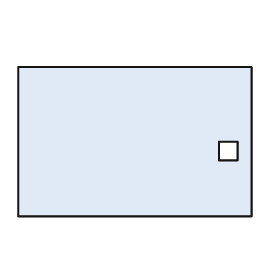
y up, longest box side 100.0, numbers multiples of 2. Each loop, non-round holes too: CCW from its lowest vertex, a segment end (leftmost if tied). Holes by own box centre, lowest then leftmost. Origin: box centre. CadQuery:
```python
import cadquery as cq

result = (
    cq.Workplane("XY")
    .moveTo(-50.0, -32.0)
    .lineTo(50.0, -32.0)
    .lineTo(50.0, 32.0)
    .lineTo(-50.0, 32.0)
    .close()
    .moveTo(36.0, -8.0)
    .lineTo(44.0, -8.0)
    .lineTo(44.0, 0.0)
    .lineTo(36.0, 0.0)
    .close()
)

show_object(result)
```